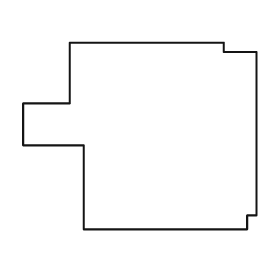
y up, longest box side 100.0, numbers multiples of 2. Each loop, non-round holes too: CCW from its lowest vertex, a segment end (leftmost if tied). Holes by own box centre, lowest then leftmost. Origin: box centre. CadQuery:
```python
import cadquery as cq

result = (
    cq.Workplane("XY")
    .moveTo(-24.0, -40.0)
    .lineTo(46.0, -40.0)
    .lineTo(46.0, -34.0)
    .lineTo(50.0, -34.0)
    .lineTo(50.0, 36.0)
    .lineTo(36.0, 36.0)
    .lineTo(36.0, 40.0)
    .lineTo(-30.0, 40.0)
    .lineTo(-30.0, 14.0)
    .lineTo(-50.0, 14.0)
    .lineTo(-50.0, -4.0)
    .lineTo(-24.0, -4.0)
    .close()
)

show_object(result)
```